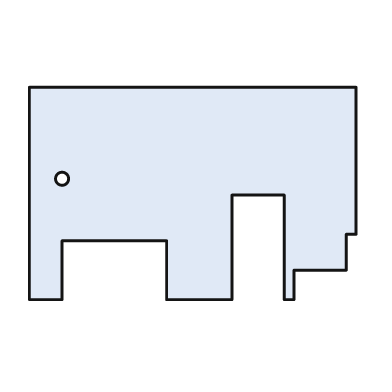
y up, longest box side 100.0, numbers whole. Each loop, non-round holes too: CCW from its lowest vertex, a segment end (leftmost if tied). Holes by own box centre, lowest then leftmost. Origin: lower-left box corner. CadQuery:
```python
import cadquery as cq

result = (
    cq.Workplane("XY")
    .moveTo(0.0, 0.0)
    .lineTo(10.0, 0.0)
    .lineTo(10.0, 18.0)
    .lineTo(42.0, 18.0)
    .lineTo(42.0, 0.0)
    .lineTo(62.0, 0.0)
    .lineTo(62.0, 32.0)
    .lineTo(78.0, 32.0)
    .lineTo(78.0, 0.0)
    .lineTo(81.0, 0.0)
    .lineTo(81.0, 9.0)
    .lineTo(97.0, 9.0)
    .lineTo(97.0, 20.0)
    .lineTo(100.0, 20.0)
    .lineTo(100.0, 65.0)
    .lineTo(0.0, 65.0)
    .close()
    .moveTo(10.0, 37.0)
    .circle(2.0)
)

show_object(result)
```